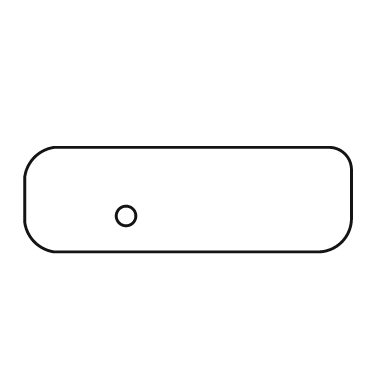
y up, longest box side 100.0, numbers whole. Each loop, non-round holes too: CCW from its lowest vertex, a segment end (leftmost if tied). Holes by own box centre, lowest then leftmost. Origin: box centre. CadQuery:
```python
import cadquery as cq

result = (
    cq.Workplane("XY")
    .moveTo(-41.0, -16.0)
    .lineTo(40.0, -16.0)
    .threePointArc((47.0, -13.0), (50.0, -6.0))
    .lineTo(50.0, 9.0)
    .threePointArc((48.0, 14.0), (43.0, 16.0))
    .lineTo(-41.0, 16.0)
    .threePointArc((-47.0, 13.0), (-50.0, 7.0))
    .lineTo(-50.0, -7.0)
    .threePointArc((-47.0, -13.0), (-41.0, -16.0))
    .close()
    .moveTo(-19.0, -5.0)
    .circle(3.0)
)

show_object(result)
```